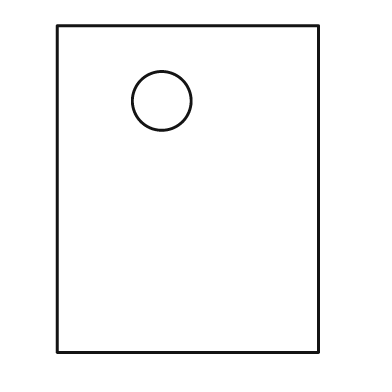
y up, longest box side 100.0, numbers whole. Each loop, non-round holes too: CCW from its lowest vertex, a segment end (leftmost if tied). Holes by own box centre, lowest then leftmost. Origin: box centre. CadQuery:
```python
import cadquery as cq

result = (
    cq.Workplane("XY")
    .moveTo(-40.0, -50.0)
    .lineTo(40.0, -50.0)
    .lineTo(40.0, 50.0)
    .lineTo(-40.0, 50.0)
    .close()
    .moveTo(-8.0, 27.0)
    .circle(9.0)
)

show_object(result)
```